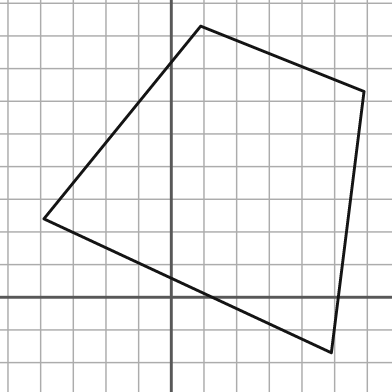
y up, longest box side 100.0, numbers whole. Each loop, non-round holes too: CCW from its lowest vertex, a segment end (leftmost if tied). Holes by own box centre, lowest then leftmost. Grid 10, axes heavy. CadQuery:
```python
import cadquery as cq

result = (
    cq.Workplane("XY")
    .moveTo(49.0, -17.0)
    .lineTo(59.0, 63.0)
    .lineTo(9.0, 83.0)
    .lineTo(-39.0, 24.0)
    .close()
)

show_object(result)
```